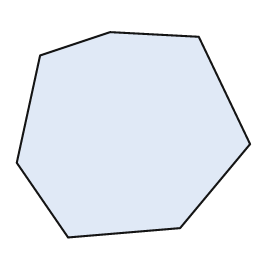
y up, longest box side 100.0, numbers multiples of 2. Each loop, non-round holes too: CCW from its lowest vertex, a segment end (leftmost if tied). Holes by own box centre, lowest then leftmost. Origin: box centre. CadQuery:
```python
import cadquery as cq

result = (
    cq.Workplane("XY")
    .moveTo(-28.0, -44.0)
    .lineTo(20.0, -40.0)
    .lineTo(50.0, -4.0)
    .lineTo(28.0, 42.0)
    .lineTo(-10.0, 44.0)
    .lineTo(-40.0, 34.0)
    .lineTo(-50.0, -12.0)
    .close()
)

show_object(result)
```